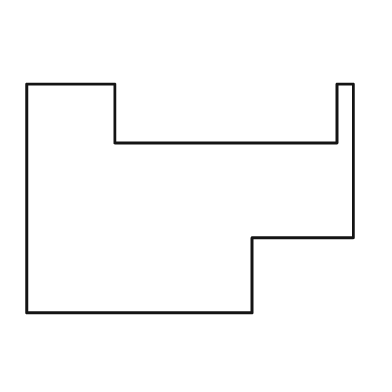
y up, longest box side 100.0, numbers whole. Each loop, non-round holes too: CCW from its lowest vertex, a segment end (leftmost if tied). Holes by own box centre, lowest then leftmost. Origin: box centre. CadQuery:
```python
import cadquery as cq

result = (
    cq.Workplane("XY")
    .moveTo(-50.0, -35.0)
    .lineTo(19.0, -35.0)
    .lineTo(19.0, -12.0)
    .lineTo(50.0, -12.0)
    .lineTo(50.0, 35.0)
    .lineTo(45.0, 35.0)
    .lineTo(45.0, 17.0)
    .lineTo(-23.0, 17.0)
    .lineTo(-23.0, 35.0)
    .lineTo(-50.0, 35.0)
    .close()
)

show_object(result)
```